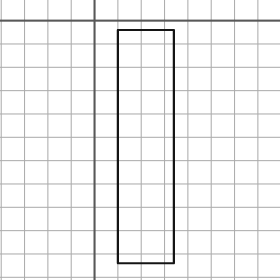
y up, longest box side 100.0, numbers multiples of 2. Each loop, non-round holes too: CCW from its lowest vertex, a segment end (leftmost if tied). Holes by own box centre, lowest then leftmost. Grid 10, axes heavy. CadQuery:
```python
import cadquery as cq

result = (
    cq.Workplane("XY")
    .moveTo(10.0, -104.0)
    .lineTo(34.0, -104.0)
    .lineTo(34.0, -4.0)
    .lineTo(10.0, -4.0)
    .close()
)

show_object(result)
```